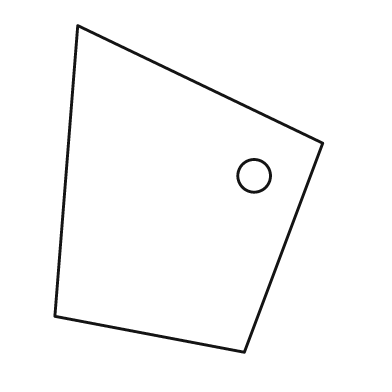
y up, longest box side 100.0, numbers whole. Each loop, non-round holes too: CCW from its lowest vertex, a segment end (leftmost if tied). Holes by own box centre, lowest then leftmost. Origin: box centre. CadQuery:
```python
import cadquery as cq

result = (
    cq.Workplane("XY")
    .moveTo(17.0, -50.0)
    .lineTo(41.0, 14.0)
    .lineTo(-34.0, 50.0)
    .lineTo(-41.0, -39.0)
    .close()
    .moveTo(20.0, 4.0)
    .circle(5.0)
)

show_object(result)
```